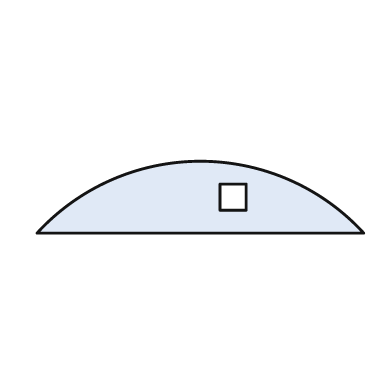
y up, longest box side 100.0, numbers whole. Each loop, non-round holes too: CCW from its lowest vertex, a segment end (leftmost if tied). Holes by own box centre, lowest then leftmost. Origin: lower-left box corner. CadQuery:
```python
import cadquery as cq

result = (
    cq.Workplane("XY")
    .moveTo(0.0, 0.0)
    .lineTo(100.0, 0.0)
    .threePointArc((50.0, 22.0), (0.0, 0.0))
    .close()
    .moveTo(56.0, 7.0)
    .lineTo(64.0, 7.0)
    .lineTo(64.0, 15.0)
    .lineTo(56.0, 15.0)
    .close()
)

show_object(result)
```